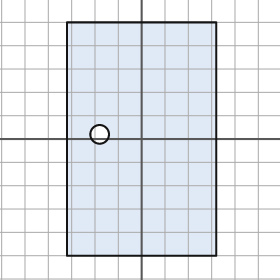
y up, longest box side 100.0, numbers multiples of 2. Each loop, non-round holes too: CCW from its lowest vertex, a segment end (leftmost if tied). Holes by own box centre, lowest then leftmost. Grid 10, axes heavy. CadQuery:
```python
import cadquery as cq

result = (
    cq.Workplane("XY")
    .moveTo(-32.0, -50.0)
    .lineTo(32.0, -50.0)
    .lineTo(32.0, 50.0)
    .lineTo(-32.0, 50.0)
    .close()
    .moveTo(-18.0, 2.0)
    .circle(4.0)
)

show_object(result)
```